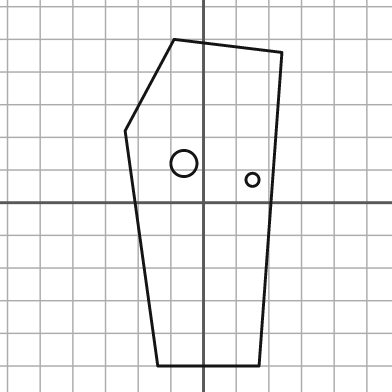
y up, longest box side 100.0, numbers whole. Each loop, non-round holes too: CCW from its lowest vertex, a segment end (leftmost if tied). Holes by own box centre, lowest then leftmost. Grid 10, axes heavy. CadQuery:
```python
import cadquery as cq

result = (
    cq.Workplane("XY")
    .moveTo(-14.0, -50.0)
    .lineTo(17.0, -50.0)
    .lineTo(24.0, 46.0)
    .lineTo(-9.0, 50.0)
    .lineTo(-24.0, 22.0)
    .close()
    .moveTo(15.0, 7.0)
    .circle(2.0)
    .moveTo(-6.0, 12.0)
    .circle(4.0)
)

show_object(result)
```